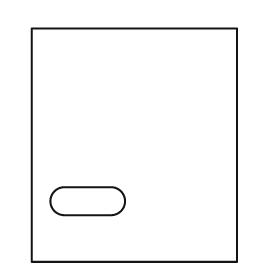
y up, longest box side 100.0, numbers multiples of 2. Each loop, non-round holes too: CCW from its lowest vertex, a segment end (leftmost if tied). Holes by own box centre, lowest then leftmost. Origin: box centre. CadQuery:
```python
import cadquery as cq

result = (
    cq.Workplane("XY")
    .moveTo(-44.0, -50.0)
    .lineTo(44.0, -50.0)
    .lineTo(44.0, 50.0)
    .lineTo(-44.0, 50.0)
    .close()
    .moveTo(-30.0, -30.0)
    .lineTo(-10.0, -30.0)
    .threePointArc((-4.0, -24.0), (-10.0, -18.0))
    .lineTo(-30.0, -18.0)
    .threePointArc((-36.0, -24.0), (-30.0, -30.0))
    .close()
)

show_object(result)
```